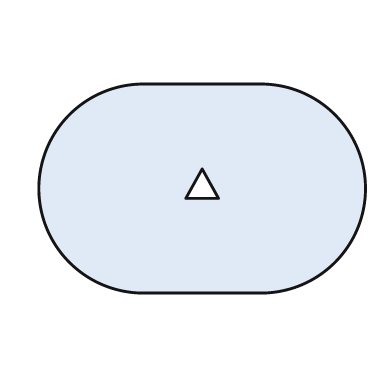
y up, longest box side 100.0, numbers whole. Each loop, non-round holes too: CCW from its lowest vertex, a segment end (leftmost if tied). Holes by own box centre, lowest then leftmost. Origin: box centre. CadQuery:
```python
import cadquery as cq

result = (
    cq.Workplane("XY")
    .moveTo(-18.0, -32.0)
    .lineTo(18.0, -32.0)
    .threePointArc((50.0, 0.0), (18.0, 32.0))
    .lineTo(-18.0, 32.0)
    .threePointArc((-50.0, 0.0), (-18.0, -32.0))
    .close()
    .moveTo(-5.0, -3.0)
    .lineTo(5.0, -3.0)
    .lineTo(0.0, 6.0)
    .close()
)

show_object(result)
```